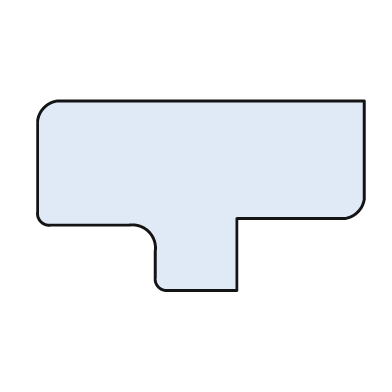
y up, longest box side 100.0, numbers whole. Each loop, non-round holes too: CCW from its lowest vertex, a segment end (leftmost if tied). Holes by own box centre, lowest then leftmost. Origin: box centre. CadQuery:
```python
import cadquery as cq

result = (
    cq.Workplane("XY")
    .moveTo(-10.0, -29.0)
    .lineTo(11.0, -29.0)
    .lineTo(11.0, -7.0)
    .lineTo(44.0, -7.0)
    .threePointArc((48.0, -5.0), (50.0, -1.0))
    .lineTo(50.0, 29.0)
    .lineTo(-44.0, 29.0)
    .threePointArc((-48.0, 27.0), (-50.0, 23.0))
    .lineTo(-50.0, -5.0)
    .threePointArc((-49.0, -8.0), (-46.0, -9.0))
    .lineTo(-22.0, -9.0)
    .threePointArc((-16.0, -11.0), (-14.0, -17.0))
    .lineTo(-14.0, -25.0)
    .threePointArc((-13.0, -28.0), (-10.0, -29.0))
    .close()
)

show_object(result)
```